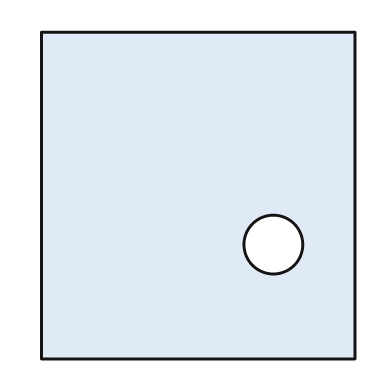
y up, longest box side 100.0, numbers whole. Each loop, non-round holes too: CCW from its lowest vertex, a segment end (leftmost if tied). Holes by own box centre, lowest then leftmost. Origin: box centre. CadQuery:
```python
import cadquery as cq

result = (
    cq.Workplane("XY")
    .moveTo(-48.0, -50.0)
    .lineTo(48.0, -50.0)
    .lineTo(48.0, 50.0)
    .lineTo(-48.0, 50.0)
    .close()
    .moveTo(23.0, -15.0)
    .circle(9.0)
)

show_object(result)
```